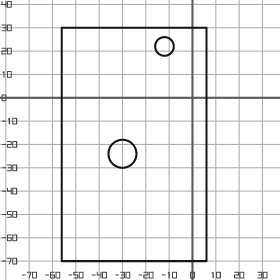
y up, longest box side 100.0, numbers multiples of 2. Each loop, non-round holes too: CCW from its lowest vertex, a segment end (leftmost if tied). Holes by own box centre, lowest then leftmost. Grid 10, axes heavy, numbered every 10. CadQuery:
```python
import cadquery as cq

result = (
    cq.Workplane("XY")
    .moveTo(-56.0, -70.0)
    .lineTo(6.0, -70.0)
    .lineTo(6.0, 30.0)
    .lineTo(-56.0, 30.0)
    .close()
    .moveTo(-30.0, -24.0)
    .circle(6.0)
    .moveTo(-12.0, 22.0)
    .circle(4.0)
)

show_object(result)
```